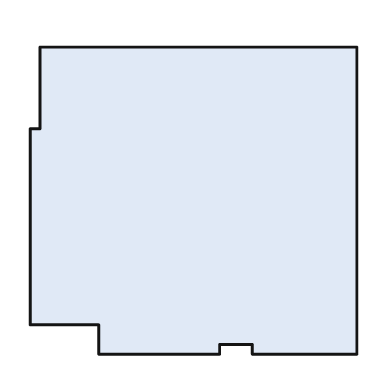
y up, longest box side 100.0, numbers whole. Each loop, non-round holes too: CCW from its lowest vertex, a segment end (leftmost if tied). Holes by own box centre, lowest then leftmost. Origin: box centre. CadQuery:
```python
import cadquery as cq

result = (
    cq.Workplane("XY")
    .moveTo(-29.0, -47.0)
    .lineTo(8.0, -47.0)
    .lineTo(8.0, -44.0)
    .lineTo(18.0, -44.0)
    .lineTo(18.0, -47.0)
    .lineTo(50.0, -47.0)
    .lineTo(50.0, 47.0)
    .lineTo(-47.0, 47.0)
    .lineTo(-47.0, 22.0)
    .lineTo(-50.0, 22.0)
    .lineTo(-50.0, -38.0)
    .lineTo(-29.0, -38.0)
    .close()
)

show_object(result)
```